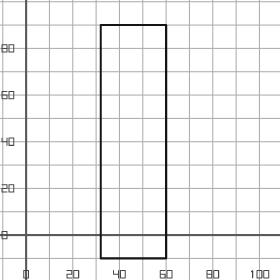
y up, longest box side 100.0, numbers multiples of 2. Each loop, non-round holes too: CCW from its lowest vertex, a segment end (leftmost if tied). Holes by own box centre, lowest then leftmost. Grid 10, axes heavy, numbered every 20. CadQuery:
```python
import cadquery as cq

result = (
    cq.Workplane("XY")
    .moveTo(32.0, -10.0)
    .lineTo(60.0, -10.0)
    .lineTo(60.0, 90.0)
    .lineTo(32.0, 90.0)
    .close()
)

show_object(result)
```